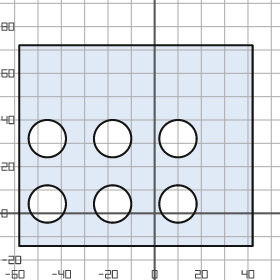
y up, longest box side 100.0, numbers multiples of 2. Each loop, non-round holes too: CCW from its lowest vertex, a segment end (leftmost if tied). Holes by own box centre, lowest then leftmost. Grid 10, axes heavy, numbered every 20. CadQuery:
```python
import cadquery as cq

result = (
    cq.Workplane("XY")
    .moveTo(-58.0, -14.0)
    .lineTo(42.0, -14.0)
    .lineTo(42.0, 72.0)
    .lineTo(-58.0, 72.0)
    .close()
    .moveTo(-46.0, 4.0)
    .circle(8.0)
    .moveTo(-18.0, 4.0)
    .circle(8.0)
    .moveTo(10.0, 4.0)
    .circle(8.0)
    .moveTo(-46.0, 32.0)
    .circle(8.0)
    .moveTo(-18.0, 32.0)
    .circle(8.0)
    .moveTo(10.0, 32.0)
    .circle(8.0)
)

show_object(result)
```